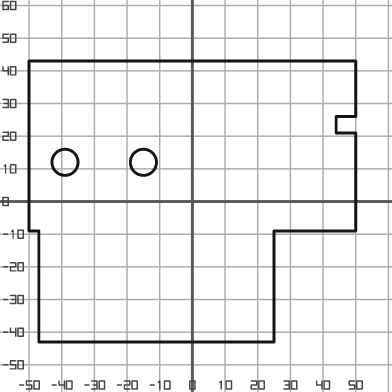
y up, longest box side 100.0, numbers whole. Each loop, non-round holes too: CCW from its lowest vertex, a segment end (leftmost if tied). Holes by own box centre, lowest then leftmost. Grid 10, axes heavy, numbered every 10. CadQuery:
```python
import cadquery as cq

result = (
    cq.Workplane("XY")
    .moveTo(-47.0, -43.0)
    .lineTo(25.0, -43.0)
    .lineTo(25.0, -9.0)
    .lineTo(50.0, -9.0)
    .lineTo(50.0, 21.0)
    .lineTo(44.0, 21.0)
    .lineTo(44.0, 26.0)
    .lineTo(50.0, 26.0)
    .lineTo(50.0, 43.0)
    .lineTo(-50.0, 43.0)
    .lineTo(-50.0, -9.0)
    .lineTo(-47.0, -9.0)
    .close()
    .moveTo(-39.0, 12.0)
    .circle(4.0)
    .moveTo(-15.0, 12.0)
    .circle(4.0)
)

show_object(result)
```